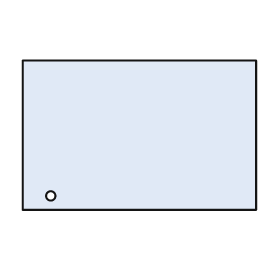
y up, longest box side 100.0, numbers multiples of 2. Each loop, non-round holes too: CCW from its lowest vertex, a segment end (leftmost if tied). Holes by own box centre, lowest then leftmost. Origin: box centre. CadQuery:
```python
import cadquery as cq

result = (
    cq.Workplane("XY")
    .moveTo(-50.0, -32.0)
    .lineTo(50.0, -32.0)
    .lineTo(50.0, 32.0)
    .lineTo(-50.0, 32.0)
    .close()
    .moveTo(-38.0, -26.0)
    .circle(2.0)
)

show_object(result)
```